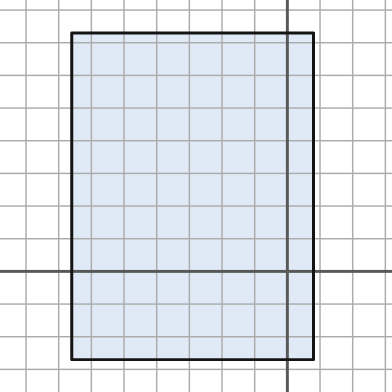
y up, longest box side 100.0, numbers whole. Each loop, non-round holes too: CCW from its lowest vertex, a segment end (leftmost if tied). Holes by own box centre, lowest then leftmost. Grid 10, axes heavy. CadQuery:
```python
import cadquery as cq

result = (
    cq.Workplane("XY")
    .moveTo(-66.0, -27.0)
    .lineTo(8.0, -27.0)
    .lineTo(8.0, 73.0)
    .lineTo(-66.0, 73.0)
    .close()
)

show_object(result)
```